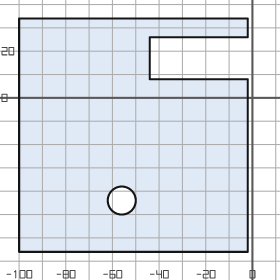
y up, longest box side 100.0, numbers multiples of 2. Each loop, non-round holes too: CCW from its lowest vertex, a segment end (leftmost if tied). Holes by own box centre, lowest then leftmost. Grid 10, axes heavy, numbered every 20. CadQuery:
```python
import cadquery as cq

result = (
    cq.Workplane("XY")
    .moveTo(-100.0, -66.0)
    .lineTo(-2.0, -66.0)
    .lineTo(-2.0, 8.0)
    .lineTo(-44.0, 8.0)
    .lineTo(-44.0, 26.0)
    .lineTo(-2.0, 26.0)
    .lineTo(-2.0, 34.0)
    .lineTo(-100.0, 34.0)
    .close()
    .moveTo(-56.0, -44.0)
    .circle(6.0)
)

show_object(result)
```